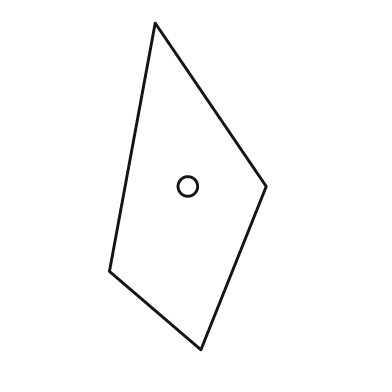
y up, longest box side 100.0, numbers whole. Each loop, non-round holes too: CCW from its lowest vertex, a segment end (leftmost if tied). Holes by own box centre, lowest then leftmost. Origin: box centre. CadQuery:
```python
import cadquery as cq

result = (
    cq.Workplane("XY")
    .moveTo(4.0, -50.0)
    .lineTo(24.0, 0.0)
    .lineTo(-10.0, 50.0)
    .lineTo(-24.0, -26.0)
    .close()
    .moveTo(0.0, 0.0)
    .circle(3.0)
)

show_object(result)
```